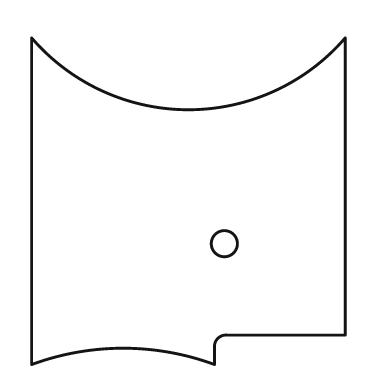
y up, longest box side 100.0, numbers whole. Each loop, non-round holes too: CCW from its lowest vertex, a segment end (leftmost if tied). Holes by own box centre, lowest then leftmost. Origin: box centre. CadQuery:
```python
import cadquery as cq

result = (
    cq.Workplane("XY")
    .moveTo(-48.0, -50.0)
    .threePointArc((-20.0, -45.0), (8.0, -50.0))
    .lineTo(8.0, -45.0)
    .threePointArc((9.0, -42.0), (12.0, -41.0))
    .lineTo(48.0, -41.0)
    .lineTo(48.0, 50.0)
    .threePointArc((0.0, 28.0), (-48.0, 50.0))
    .close()
    .moveTo(11.0, -13.0)
    .circle(4.0)
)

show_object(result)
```